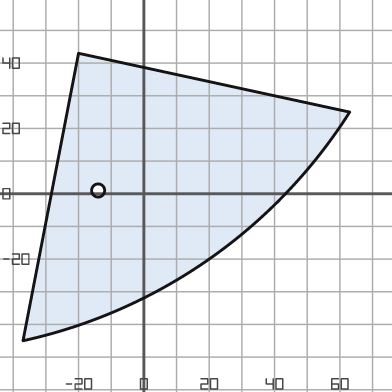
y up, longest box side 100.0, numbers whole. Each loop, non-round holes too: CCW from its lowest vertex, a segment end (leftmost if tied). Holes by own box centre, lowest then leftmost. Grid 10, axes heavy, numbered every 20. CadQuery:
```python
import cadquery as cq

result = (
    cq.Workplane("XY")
    .moveTo(-37.0, -45.0)
    .threePointArc((20.0, -20.0), (63.0, 25.0))
    .lineTo(-20.0, 43.0)
    .close()
    .moveTo(-14.0, 1.0)
    .circle(2.0)
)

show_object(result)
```